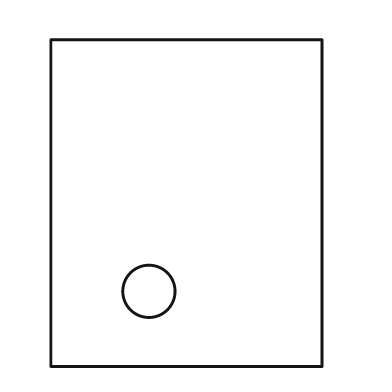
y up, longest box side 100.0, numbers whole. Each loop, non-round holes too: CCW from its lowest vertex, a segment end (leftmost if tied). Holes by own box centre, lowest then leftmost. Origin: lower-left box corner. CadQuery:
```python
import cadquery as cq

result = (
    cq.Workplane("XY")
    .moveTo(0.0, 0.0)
    .lineTo(83.0, 0.0)
    .lineTo(83.0, 100.0)
    .lineTo(0.0, 100.0)
    .close()
    .moveTo(30.0, 23.0)
    .circle(8.0)
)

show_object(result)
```